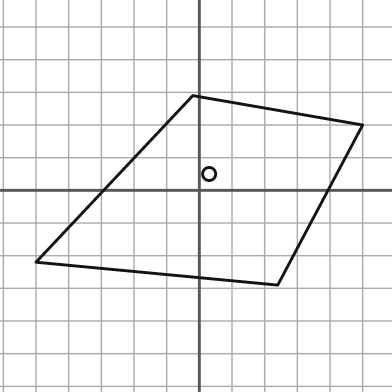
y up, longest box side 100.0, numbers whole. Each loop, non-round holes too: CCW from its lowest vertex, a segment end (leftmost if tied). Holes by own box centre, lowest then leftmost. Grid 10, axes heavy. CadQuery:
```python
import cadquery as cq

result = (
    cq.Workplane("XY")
    .moveTo(24.0, -29.0)
    .lineTo(50.0, 20.0)
    .lineTo(-2.0, 29.0)
    .lineTo(-50.0, -22.0)
    .close()
    .moveTo(3.0, 5.0)
    .circle(2.0)
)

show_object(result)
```